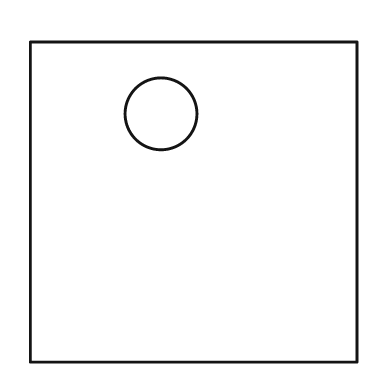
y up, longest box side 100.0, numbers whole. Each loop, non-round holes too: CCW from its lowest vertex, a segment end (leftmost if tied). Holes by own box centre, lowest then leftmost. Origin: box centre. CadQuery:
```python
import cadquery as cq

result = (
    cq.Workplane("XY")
    .moveTo(-50.0, -49.0)
    .lineTo(50.0, -49.0)
    .lineTo(50.0, 49.0)
    .lineTo(-50.0, 49.0)
    .close()
    .moveTo(-10.0, 27.0)
    .circle(11.0)
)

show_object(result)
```